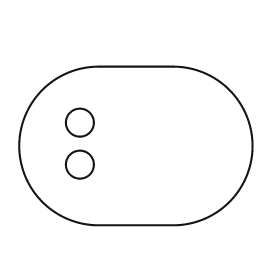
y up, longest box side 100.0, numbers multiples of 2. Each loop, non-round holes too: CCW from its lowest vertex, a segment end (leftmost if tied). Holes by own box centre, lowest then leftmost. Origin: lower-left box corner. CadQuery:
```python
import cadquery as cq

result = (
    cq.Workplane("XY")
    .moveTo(34.0, 0.0)
    .lineTo(66.0, 0.0)
    .threePointArc((100.0, 34.0), (66.0, 68.0))
    .lineTo(34.0, 68.0)
    .threePointArc((0.0, 34.0), (34.0, 0.0))
    .close()
    .moveTo(26.0, 26.0)
    .circle(6.0)
    .moveTo(26.0, 44.0)
    .circle(6.0)
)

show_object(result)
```